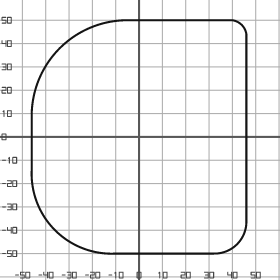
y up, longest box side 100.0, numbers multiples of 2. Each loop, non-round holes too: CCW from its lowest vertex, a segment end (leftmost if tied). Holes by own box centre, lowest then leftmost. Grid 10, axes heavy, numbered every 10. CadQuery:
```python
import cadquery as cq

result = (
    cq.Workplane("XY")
    .moveTo(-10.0, -50.0)
    .lineTo(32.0, -50.0)
    .threePointArc((42.0, -46.0), (46.0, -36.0))
    .lineTo(46.0, 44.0)
    .threePointArc((44.0, 48.0), (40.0, 50.0))
    .lineTo(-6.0, 50.0)
    .threePointArc((-34.0, 38.0), (-46.0, 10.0))
    .lineTo(-46.0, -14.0)
    .threePointArc((-36.0, -40.0), (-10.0, -50.0))
    .close()
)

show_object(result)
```